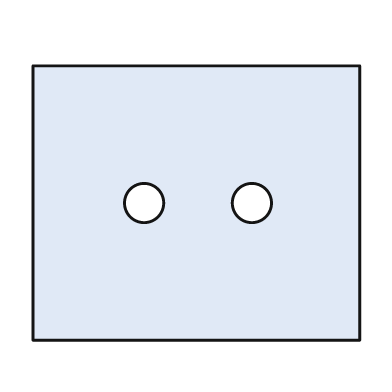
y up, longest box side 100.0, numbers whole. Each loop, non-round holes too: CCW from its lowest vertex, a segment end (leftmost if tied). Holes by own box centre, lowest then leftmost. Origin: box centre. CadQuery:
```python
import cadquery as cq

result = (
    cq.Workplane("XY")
    .moveTo(-50.0, -42.0)
    .lineTo(50.0, -42.0)
    .lineTo(50.0, 42.0)
    .lineTo(-50.0, 42.0)
    .close()
    .moveTo(-16.0, 0.0)
    .circle(6.0)
    .moveTo(17.0, 0.0)
    .circle(6.0)
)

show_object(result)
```